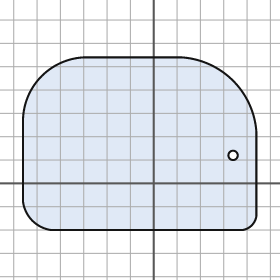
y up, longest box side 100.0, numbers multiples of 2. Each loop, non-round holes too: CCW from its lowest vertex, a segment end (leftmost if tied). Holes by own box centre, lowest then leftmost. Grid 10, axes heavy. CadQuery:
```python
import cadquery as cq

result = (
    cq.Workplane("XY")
    .moveTo(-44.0, -20.0)
    .lineTo(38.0, -20.0)
    .threePointArc((42.0, -18.0), (44.0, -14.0))
    .lineTo(44.0, 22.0)
    .threePointArc((34.0, 44.0), (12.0, 54.0))
    .lineTo(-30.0, 54.0)
    .threePointArc((-48.0, 46.0), (-56.0, 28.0))
    .lineTo(-56.0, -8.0)
    .threePointArc((-52.0, -16.0), (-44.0, -20.0))
    .close()
    .moveTo(34.0, 12.0)
    .circle(2.0)
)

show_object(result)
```